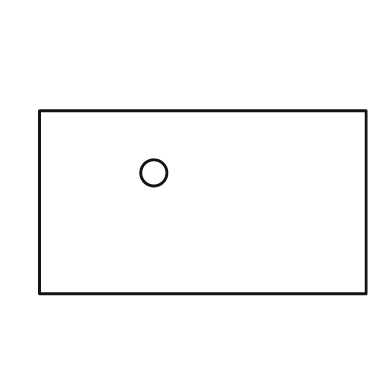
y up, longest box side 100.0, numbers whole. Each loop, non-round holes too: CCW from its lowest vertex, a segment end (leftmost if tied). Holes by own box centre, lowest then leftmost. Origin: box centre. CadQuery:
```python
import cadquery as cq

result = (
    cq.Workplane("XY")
    .moveTo(-50.0, -28.0)
    .lineTo(50.0, -28.0)
    .lineTo(50.0, 28.0)
    .lineTo(-50.0, 28.0)
    .close()
    .moveTo(-15.0, 9.0)
    .circle(4.0)
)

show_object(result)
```